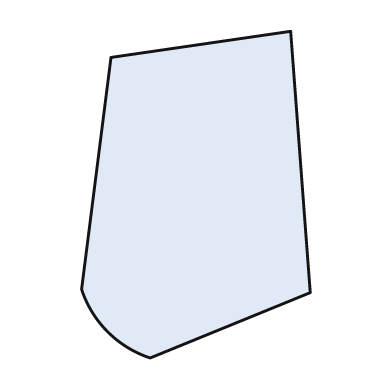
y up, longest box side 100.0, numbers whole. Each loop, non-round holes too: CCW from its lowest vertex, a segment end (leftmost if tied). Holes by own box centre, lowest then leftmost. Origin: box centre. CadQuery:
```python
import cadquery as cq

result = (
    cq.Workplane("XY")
    .moveTo(-14.0, -50.0)
    .lineTo(35.0, -30.0)
    .lineTo(29.0, 50.0)
    .lineTo(-26.0, 42.0)
    .lineTo(-35.0, -29.0)
    .threePointArc((-27.0, -42.0), (-14.0, -50.0))
    .close()
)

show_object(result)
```